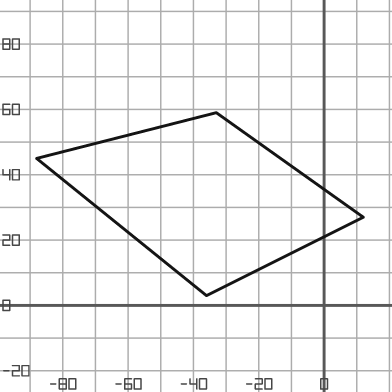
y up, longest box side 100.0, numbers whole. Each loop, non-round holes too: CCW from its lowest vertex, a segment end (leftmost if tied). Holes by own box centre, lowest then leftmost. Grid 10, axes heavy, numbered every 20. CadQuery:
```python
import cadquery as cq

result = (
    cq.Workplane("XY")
    .moveTo(-36.0, 3.0)
    .lineTo(12.0, 27.0)
    .lineTo(-33.0, 59.0)
    .lineTo(-88.0, 45.0)
    .close()
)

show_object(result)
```